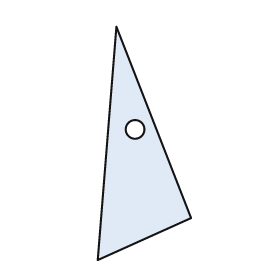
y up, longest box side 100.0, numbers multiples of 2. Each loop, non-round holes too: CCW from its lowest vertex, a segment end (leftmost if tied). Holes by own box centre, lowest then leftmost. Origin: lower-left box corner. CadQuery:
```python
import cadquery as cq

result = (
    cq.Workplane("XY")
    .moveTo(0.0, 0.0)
    .lineTo(40.0, 18.0)
    .lineTo(8.0, 100.0)
    .close()
    .moveTo(16.0, 56.0)
    .circle(4.0)
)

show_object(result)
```